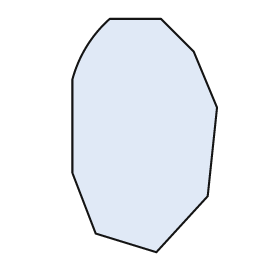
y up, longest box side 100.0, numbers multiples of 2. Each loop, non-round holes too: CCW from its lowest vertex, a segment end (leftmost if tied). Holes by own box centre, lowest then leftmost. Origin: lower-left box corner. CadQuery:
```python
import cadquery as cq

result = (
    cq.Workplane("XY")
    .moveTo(36.0, 0.0)
    .lineTo(58.0, 24.0)
    .lineTo(62.0, 62.0)
    .lineTo(52.0, 86.0)
    .lineTo(38.0, 100.0)
    .lineTo(16.0, 100.0)
    .threePointArc((6.0, 88.0), (0.0, 74.0))
    .lineTo(0.0, 34.0)
    .lineTo(10.0, 8.0)
    .close()
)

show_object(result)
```